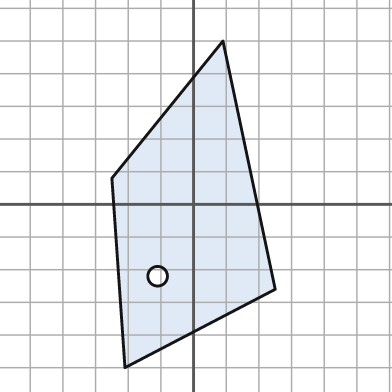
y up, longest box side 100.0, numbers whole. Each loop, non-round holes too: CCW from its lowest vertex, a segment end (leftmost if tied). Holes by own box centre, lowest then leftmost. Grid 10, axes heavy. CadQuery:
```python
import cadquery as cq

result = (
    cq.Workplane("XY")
    .moveTo(-21.0, -50.0)
    .lineTo(25.0, -26.0)
    .lineTo(9.0, 50.0)
    .lineTo(-25.0, 8.0)
    .close()
    .moveTo(-11.0, -22.0)
    .circle(3.0)
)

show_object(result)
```